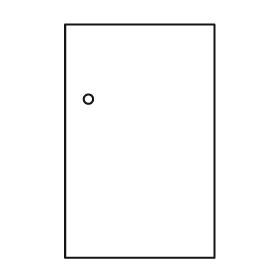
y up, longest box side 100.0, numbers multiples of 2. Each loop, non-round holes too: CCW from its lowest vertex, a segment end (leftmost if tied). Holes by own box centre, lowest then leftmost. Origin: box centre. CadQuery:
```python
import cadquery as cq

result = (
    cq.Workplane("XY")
    .moveTo(-32.0, -50.0)
    .lineTo(32.0, -50.0)
    .lineTo(32.0, 50.0)
    .lineTo(-32.0, 50.0)
    .close()
    .moveTo(-22.0, 18.0)
    .circle(2.0)
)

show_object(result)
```